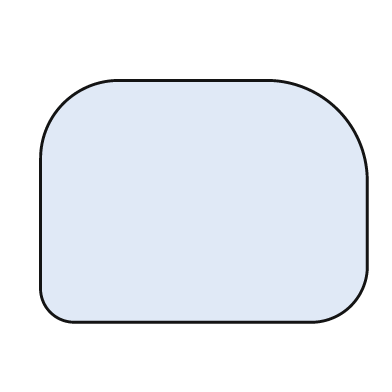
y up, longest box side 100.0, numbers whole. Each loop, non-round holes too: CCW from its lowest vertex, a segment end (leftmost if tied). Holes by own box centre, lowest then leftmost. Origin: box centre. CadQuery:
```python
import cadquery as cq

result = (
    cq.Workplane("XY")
    .moveTo(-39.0, -37.0)
    .lineTo(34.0, -37.0)
    .threePointArc((45.0, -32.0), (50.0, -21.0))
    .lineTo(50.0, 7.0)
    .threePointArc((41.0, 28.0), (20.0, 37.0))
    .lineTo(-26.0, 37.0)
    .threePointArc((-43.0, 30.0), (-50.0, 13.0))
    .lineTo(-50.0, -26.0)
    .threePointArc((-47.0, -34.0), (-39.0, -37.0))
    .close()
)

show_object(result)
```